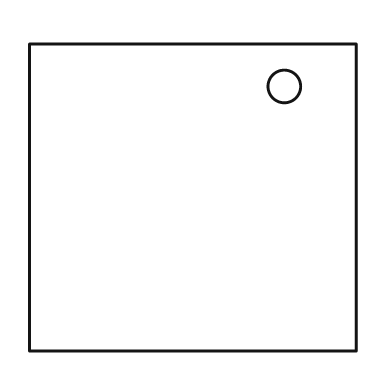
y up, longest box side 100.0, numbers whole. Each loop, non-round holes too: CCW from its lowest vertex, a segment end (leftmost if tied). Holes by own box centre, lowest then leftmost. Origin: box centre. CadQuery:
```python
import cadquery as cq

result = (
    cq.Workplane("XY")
    .moveTo(-50.0, -47.0)
    .lineTo(50.0, -47.0)
    .lineTo(50.0, 47.0)
    .lineTo(-50.0, 47.0)
    .close()
    .moveTo(28.0, 34.0)
    .circle(5.0)
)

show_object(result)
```